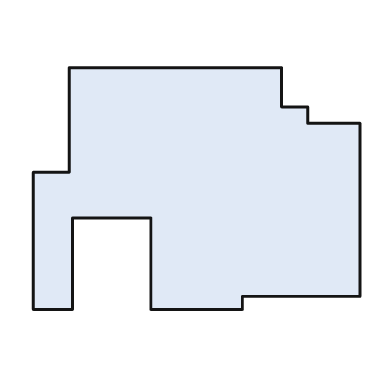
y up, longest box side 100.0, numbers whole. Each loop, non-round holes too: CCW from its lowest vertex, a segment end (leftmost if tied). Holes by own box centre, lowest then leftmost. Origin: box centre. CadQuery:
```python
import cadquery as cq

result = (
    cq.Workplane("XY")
    .moveTo(-50.0, -37.0)
    .lineTo(-38.0, -37.0)
    .lineTo(-38.0, -9.0)
    .lineTo(-14.0, -9.0)
    .lineTo(-14.0, -37.0)
    .lineTo(14.0, -37.0)
    .lineTo(14.0, -33.0)
    .lineTo(50.0, -33.0)
    .lineTo(50.0, 20.0)
    .lineTo(34.0, 20.0)
    .lineTo(34.0, 25.0)
    .lineTo(26.0, 25.0)
    .lineTo(26.0, 37.0)
    .lineTo(-39.0, 37.0)
    .lineTo(-39.0, 5.0)
    .lineTo(-50.0, 5.0)
    .close()
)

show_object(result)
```